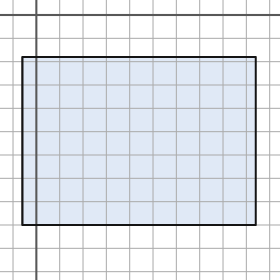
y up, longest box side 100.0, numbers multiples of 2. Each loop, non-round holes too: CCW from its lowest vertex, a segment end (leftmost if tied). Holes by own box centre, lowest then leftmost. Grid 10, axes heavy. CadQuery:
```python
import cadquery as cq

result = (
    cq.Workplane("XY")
    .moveTo(-6.0, -90.0)
    .lineTo(94.0, -90.0)
    .lineTo(94.0, -18.0)
    .lineTo(-6.0, -18.0)
    .close()
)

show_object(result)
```